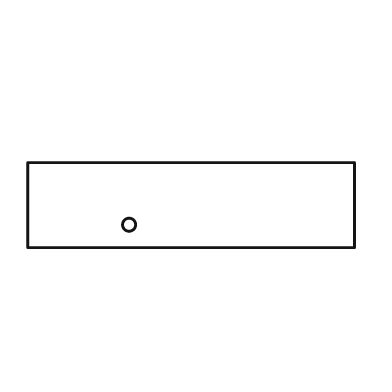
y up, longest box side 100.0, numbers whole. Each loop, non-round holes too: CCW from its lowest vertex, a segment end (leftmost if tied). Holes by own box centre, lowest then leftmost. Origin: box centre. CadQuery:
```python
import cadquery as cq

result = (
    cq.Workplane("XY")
    .moveTo(-50.0, -13.0)
    .lineTo(50.0, -13.0)
    .lineTo(50.0, 13.0)
    .lineTo(-50.0, 13.0)
    .close()
    .moveTo(-19.0, -6.0)
    .circle(2.0)
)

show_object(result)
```